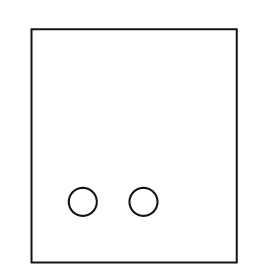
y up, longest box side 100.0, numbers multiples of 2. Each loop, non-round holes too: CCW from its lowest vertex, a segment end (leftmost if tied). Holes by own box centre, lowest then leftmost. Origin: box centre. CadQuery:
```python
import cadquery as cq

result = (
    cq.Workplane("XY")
    .moveTo(-44.0, -50.0)
    .lineTo(44.0, -50.0)
    .lineTo(44.0, 50.0)
    .lineTo(-44.0, 50.0)
    .close()
    .moveTo(-22.0, -24.0)
    .circle(6.0)
    .moveTo(4.0, -24.0)
    .circle(6.0)
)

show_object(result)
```